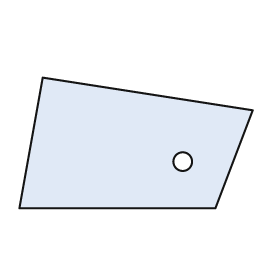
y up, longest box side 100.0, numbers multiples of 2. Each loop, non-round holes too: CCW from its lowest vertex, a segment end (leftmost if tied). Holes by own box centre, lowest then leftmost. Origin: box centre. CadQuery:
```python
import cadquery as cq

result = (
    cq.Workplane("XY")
    .moveTo(-50.0, -28.0)
    .lineTo(34.0, -28.0)
    .lineTo(50.0, 14.0)
    .lineTo(-40.0, 28.0)
    .close()
    .moveTo(20.0, -8.0)
    .circle(4.0)
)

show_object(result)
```